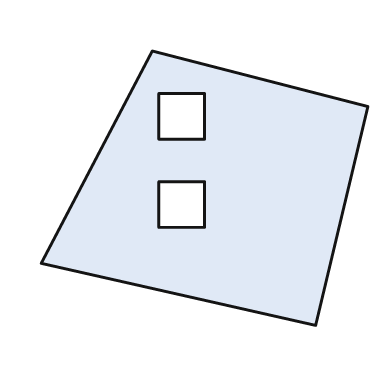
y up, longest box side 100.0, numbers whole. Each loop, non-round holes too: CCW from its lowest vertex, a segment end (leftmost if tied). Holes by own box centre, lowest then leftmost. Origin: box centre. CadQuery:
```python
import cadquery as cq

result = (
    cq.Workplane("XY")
    .moveTo(34.0, -42.0)
    .lineTo(50.0, 25.0)
    .lineTo(-16.0, 42.0)
    .lineTo(-50.0, -23.0)
    .close()
    .moveTo(-14.0, -12.0)
    .lineTo(0.0, -12.0)
    .lineTo(0.0, 2.0)
    .lineTo(-14.0, 2.0)
    .close()
    .moveTo(-14.0, 15.0)
    .lineTo(0.0, 15.0)
    .lineTo(0.0, 29.0)
    .lineTo(-14.0, 29.0)
    .close()
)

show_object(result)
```